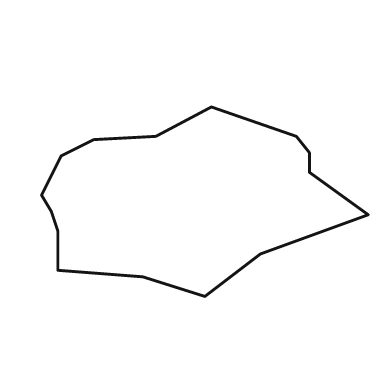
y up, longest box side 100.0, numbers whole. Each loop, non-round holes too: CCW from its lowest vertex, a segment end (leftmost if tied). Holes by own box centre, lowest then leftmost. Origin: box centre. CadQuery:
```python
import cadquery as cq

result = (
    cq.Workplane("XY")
    .moveTo(0.0, -29.0)
    .lineTo(17.0, -16.0)
    .lineTo(50.0, -4.0)
    .lineTo(32.0, 9.0)
    .lineTo(32.0, 15.0)
    .lineTo(28.0, 20.0)
    .lineTo(2.0, 29.0)
    .lineTo(-15.0, 20.0)
    .lineTo(-34.0, 19.0)
    .lineTo(-44.0, 14.0)
    .lineTo(-50.0, 2.0)
    .lineTo(-47.0, -3.0)
    .lineTo(-45.0, -9.0)
    .lineTo(-45.0, -21.0)
    .lineTo(-19.0, -23.0)
    .close()
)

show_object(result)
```